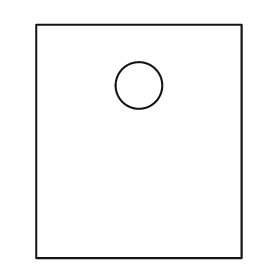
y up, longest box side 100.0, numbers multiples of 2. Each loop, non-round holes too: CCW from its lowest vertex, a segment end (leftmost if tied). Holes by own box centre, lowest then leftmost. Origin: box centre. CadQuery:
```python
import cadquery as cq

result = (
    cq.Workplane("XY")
    .moveTo(-44.0, -50.0)
    .lineTo(44.0, -50.0)
    .lineTo(44.0, 50.0)
    .lineTo(-44.0, 50.0)
    .close()
    .moveTo(0.0, 24.0)
    .circle(10.0)
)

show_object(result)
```